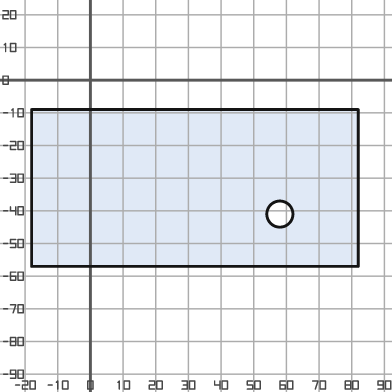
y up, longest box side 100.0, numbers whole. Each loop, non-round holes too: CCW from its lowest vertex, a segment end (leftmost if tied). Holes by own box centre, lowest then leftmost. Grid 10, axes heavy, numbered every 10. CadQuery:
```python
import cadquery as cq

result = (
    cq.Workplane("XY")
    .moveTo(-18.0, -57.0)
    .lineTo(82.0, -57.0)
    .lineTo(82.0, -9.0)
    .lineTo(-18.0, -9.0)
    .close()
    .moveTo(58.0, -41.0)
    .circle(4.0)
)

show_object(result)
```